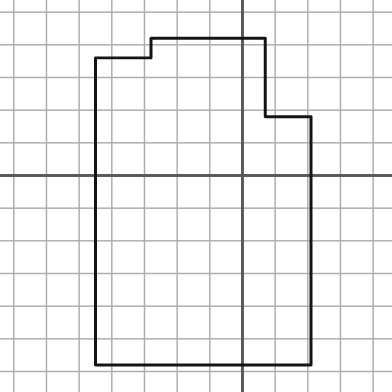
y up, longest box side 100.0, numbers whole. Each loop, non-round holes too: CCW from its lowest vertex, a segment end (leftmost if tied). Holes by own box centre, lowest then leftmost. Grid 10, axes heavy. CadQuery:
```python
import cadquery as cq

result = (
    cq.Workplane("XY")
    .moveTo(-45.0, -58.0)
    .lineTo(21.0, -58.0)
    .lineTo(21.0, 18.0)
    .lineTo(7.0, 18.0)
    .lineTo(7.0, 42.0)
    .lineTo(-28.0, 42.0)
    .lineTo(-28.0, 36.0)
    .lineTo(-45.0, 36.0)
    .close()
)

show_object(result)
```